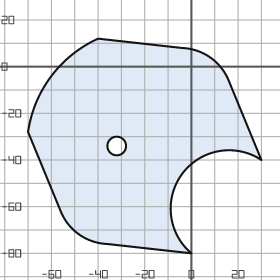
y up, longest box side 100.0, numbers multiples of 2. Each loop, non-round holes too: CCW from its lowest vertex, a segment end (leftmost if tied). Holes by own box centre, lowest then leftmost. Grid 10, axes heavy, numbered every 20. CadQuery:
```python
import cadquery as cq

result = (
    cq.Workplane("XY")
    .moveTo(0.0, -80.0)
    .threePointArc((-4.0, -46.0), (30.0, -40.0))
    .lineTo(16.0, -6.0)
    .threePointArc((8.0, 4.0), (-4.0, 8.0))
    .lineTo(-40.0, 12.0)
    .threePointArc((-60.0, -4.0), (-70.0, -28.0))
    .lineTo(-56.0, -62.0)
    .threePointArc((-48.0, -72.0), (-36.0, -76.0))
    .close()
    .moveTo(-32.0, -34.0)
    .circle(4.0)
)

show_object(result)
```